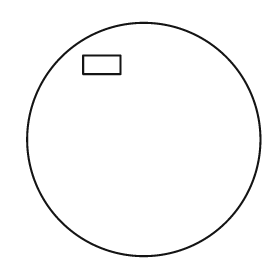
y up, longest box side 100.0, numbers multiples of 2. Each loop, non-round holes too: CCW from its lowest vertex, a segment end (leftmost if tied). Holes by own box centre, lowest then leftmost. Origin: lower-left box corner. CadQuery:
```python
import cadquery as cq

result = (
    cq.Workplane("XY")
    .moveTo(50.0, 50.0)
    .circle(50.0)
    .moveTo(24.0, 78.0)
    .lineTo(40.0, 78.0)
    .lineTo(40.0, 86.0)
    .lineTo(24.0, 86.0)
    .close()
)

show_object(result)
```